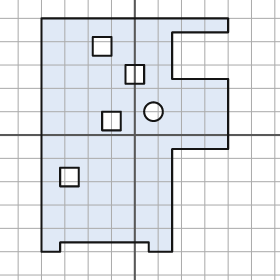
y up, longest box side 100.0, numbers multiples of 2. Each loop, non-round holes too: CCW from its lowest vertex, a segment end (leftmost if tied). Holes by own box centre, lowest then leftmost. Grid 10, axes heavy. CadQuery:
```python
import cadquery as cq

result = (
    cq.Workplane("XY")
    .moveTo(-40.0, -50.0)
    .lineTo(-32.0, -50.0)
    .lineTo(-32.0, -46.0)
    .lineTo(6.0, -46.0)
    .lineTo(6.0, -50.0)
    .lineTo(16.0, -50.0)
    .lineTo(16.0, -6.0)
    .lineTo(40.0, -6.0)
    .lineTo(40.0, 24.0)
    .lineTo(16.0, 24.0)
    .lineTo(16.0, 44.0)
    .lineTo(40.0, 44.0)
    .lineTo(40.0, 50.0)
    .lineTo(-40.0, 50.0)
    .close()
    .moveTo(-32.0, -22.0)
    .lineTo(-24.0, -22.0)
    .lineTo(-24.0, -14.0)
    .lineTo(-32.0, -14.0)
    .close()
    .moveTo(-14.0, 2.0)
    .lineTo(-6.0, 2.0)
    .lineTo(-6.0, 10.0)
    .lineTo(-14.0, 10.0)
    .close()
    .moveTo(8.0, 10.0)
    .circle(4.0)
    .moveTo(-4.0, 22.0)
    .lineTo(4.0, 22.0)
    .lineTo(4.0, 30.0)
    .lineTo(-4.0, 30.0)
    .close()
    .moveTo(-18.0, 34.0)
    .lineTo(-10.0, 34.0)
    .lineTo(-10.0, 42.0)
    .lineTo(-18.0, 42.0)
    .close()
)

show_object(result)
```